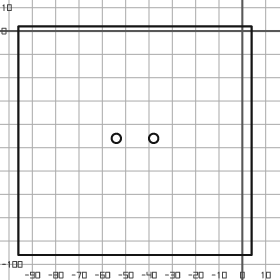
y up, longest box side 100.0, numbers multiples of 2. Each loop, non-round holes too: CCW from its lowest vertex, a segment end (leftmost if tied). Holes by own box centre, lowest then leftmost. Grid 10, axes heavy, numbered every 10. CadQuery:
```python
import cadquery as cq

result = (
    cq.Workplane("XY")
    .moveTo(-96.0, -96.0)
    .lineTo(4.0, -96.0)
    .lineTo(4.0, 2.0)
    .lineTo(-96.0, 2.0)
    .close()
    .moveTo(-54.0, -46.0)
    .circle(2.0)
    .moveTo(-38.0, -46.0)
    .circle(2.0)
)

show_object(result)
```